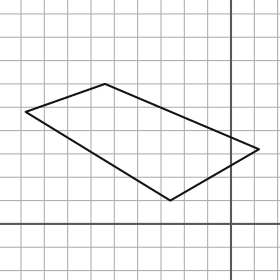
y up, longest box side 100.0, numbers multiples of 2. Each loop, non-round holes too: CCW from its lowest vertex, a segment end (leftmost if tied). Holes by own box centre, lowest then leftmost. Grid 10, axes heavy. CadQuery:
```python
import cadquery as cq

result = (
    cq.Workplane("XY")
    .moveTo(-26.0, 10.0)
    .lineTo(12.0, 32.0)
    .lineTo(-54.0, 60.0)
    .lineTo(-88.0, 48.0)
    .close()
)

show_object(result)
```